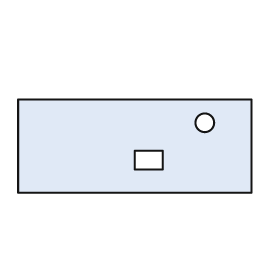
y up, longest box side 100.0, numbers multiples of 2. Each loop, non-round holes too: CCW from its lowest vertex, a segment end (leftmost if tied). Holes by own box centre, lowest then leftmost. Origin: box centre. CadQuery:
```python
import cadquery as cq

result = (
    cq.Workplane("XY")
    .moveTo(-50.0, -20.0)
    .lineTo(50.0, -20.0)
    .lineTo(50.0, 20.0)
    .lineTo(-50.0, 20.0)
    .close()
    .moveTo(0.0, -10.0)
    .lineTo(12.0, -10.0)
    .lineTo(12.0, -2.0)
    .lineTo(0.0, -2.0)
    .close()
    .moveTo(30.0, 10.0)
    .circle(4.0)
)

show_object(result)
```